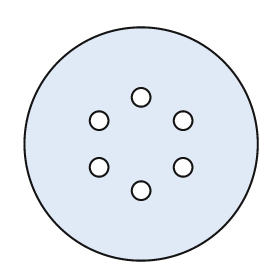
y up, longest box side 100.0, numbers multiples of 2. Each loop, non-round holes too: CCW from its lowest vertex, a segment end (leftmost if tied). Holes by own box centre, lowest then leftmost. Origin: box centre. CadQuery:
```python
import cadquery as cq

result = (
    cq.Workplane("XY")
    .moveTo(0.0, 0.0)
    .circle(50.0)
    .moveTo(0.0, -20.0)
    .circle(4.0)
    .moveTo(-18.0, -10.0)
    .circle(4.0)
    .moveTo(18.0, -10.0)
    .circle(4.0)
    .moveTo(-18.0, 10.0)
    .circle(4.0)
    .moveTo(18.0, 10.0)
    .circle(4.0)
    .moveTo(0.0, 20.0)
    .circle(4.0)
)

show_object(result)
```